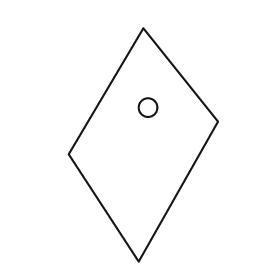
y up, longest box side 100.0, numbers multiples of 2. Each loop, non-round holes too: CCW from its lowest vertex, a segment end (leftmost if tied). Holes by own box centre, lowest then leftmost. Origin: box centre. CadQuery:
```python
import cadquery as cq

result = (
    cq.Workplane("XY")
    .moveTo(-2.0, -50.0)
    .lineTo(32.0, 10.0)
    .lineTo(0.0, 50.0)
    .lineTo(-32.0, -4.0)
    .close()
    .moveTo(2.0, 16.0)
    .circle(4.0)
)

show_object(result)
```